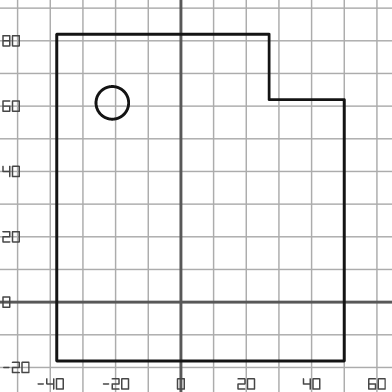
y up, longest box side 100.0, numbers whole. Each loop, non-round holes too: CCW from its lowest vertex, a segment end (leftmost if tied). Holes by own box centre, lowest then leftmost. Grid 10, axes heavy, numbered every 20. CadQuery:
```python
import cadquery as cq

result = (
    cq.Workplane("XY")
    .moveTo(-38.0, -18.0)
    .lineTo(50.0, -18.0)
    .lineTo(50.0, 62.0)
    .lineTo(27.0, 62.0)
    .lineTo(27.0, 82.0)
    .lineTo(-38.0, 82.0)
    .close()
    .moveTo(-21.0, 61.0)
    .circle(5.0)
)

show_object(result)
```